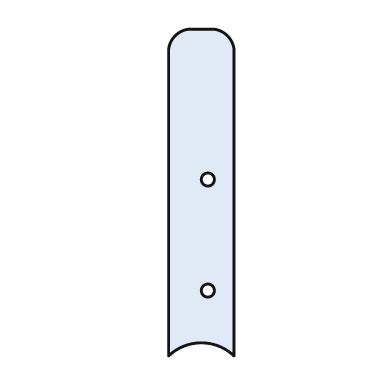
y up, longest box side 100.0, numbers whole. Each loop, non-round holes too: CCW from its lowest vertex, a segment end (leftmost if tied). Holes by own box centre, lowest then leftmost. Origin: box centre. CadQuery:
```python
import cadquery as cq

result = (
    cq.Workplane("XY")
    .moveTo(-10.0, -50.0)
    .threePointArc((0.0, -46.0), (10.0, -50.0))
    .lineTo(10.0, 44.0)
    .threePointArc((8.0, 48.0), (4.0, 50.0))
    .lineTo(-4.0, 50.0)
    .threePointArc((-8.0, 48.0), (-10.0, 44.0))
    .close()
    .moveTo(2.0, -30.0)
    .circle(2.0)
    .moveTo(2.0, 4.0)
    .circle(2.0)
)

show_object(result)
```